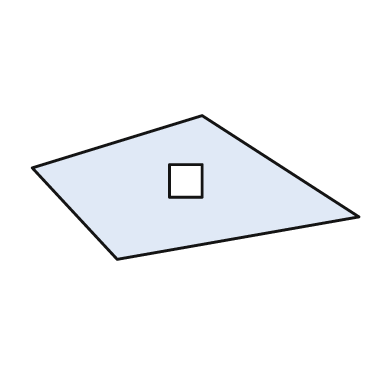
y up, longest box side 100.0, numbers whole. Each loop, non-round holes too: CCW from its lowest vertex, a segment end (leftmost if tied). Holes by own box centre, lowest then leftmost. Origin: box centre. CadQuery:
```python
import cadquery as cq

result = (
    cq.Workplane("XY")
    .moveTo(-24.0, -22.0)
    .lineTo(50.0, -9.0)
    .lineTo(2.0, 22.0)
    .lineTo(-50.0, 6.0)
    .close()
    .moveTo(-8.0, -3.0)
    .lineTo(2.0, -3.0)
    .lineTo(2.0, 7.0)
    .lineTo(-8.0, 7.0)
    .close()
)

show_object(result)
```